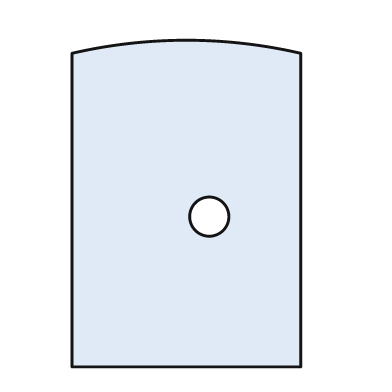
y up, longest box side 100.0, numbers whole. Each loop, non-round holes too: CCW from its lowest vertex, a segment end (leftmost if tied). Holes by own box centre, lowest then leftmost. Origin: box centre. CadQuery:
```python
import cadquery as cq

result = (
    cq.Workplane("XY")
    .moveTo(-35.0, -50.0)
    .lineTo(35.0, -50.0)
    .lineTo(35.0, 46.0)
    .threePointArc((0.0, 50.0), (-35.0, 46.0))
    .close()
    .moveTo(7.0, -4.0)
    .circle(6.0)
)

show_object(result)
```